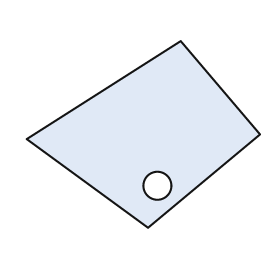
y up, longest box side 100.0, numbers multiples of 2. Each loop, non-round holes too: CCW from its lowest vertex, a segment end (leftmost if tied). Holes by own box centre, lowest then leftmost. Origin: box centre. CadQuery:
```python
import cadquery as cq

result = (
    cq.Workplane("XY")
    .moveTo(2.0, -40.0)
    .lineTo(50.0, 0.0)
    .lineTo(16.0, 40.0)
    .lineTo(-50.0, -2.0)
    .close()
    .moveTo(6.0, -22.0)
    .circle(6.0)
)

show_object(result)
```